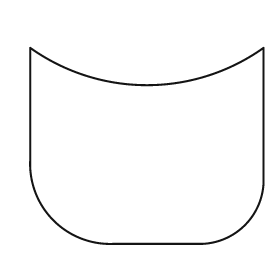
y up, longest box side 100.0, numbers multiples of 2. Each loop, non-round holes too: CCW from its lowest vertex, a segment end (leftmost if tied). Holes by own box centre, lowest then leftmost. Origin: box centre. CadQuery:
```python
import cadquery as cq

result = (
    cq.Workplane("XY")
    .moveTo(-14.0, -42.0)
    .lineTo(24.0, -42.0)
    .threePointArc((42.0, -34.0), (50.0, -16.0))
    .lineTo(50.0, 42.0)
    .threePointArc((0.0, 26.0), (-50.0, 42.0))
    .lineTo(-50.0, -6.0)
    .threePointArc((-40.0, -32.0), (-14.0, -42.0))
    .close()
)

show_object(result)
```